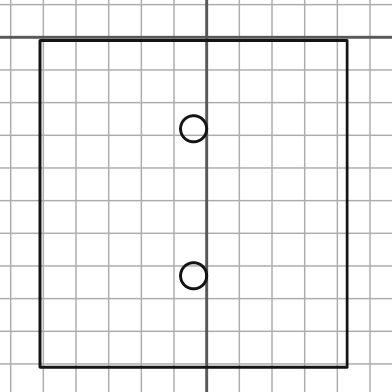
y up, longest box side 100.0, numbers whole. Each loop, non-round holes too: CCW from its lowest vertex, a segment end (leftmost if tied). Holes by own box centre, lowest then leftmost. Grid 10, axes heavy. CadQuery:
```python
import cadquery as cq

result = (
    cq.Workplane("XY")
    .moveTo(-51.0, -101.0)
    .lineTo(43.0, -101.0)
    .lineTo(43.0, -1.0)
    .lineTo(-51.0, -1.0)
    .close()
    .moveTo(-4.0, -73.0)
    .circle(4.0)
    .moveTo(-4.0, -28.0)
    .circle(4.0)
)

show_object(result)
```